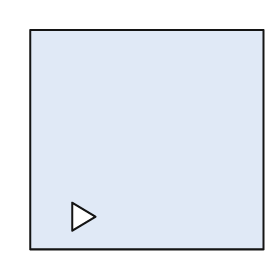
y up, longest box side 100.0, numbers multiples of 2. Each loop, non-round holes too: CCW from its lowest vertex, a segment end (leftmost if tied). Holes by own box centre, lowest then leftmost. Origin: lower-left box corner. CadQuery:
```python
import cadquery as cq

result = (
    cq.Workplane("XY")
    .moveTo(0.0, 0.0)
    .lineTo(100.0, 0.0)
    .lineTo(100.0, 94.0)
    .lineTo(0.0, 94.0)
    .close()
    .moveTo(18.0, 8.0)
    .lineTo(28.0, 14.0)
    .lineTo(18.0, 20.0)
    .close()
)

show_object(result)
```